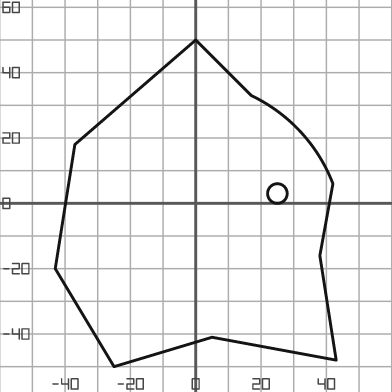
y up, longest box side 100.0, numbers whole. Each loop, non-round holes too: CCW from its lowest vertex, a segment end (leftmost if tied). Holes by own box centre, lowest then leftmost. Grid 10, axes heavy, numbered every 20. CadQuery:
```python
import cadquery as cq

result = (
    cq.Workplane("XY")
    .moveTo(-25.0, -50.0)
    .lineTo(5.0, -41.0)
    .lineTo(43.0, -48.0)
    .lineTo(38.0, -16.0)
    .lineTo(42.0, 6.0)
    .threePointArc((32.0, 22.0), (17.0, 33.0))
    .lineTo(0.0, 50.0)
    .lineTo(-37.0, 18.0)
    .lineTo(-43.0, -20.0)
    .close()
    .moveTo(25.0, 3.0)
    .circle(3.0)
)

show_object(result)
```